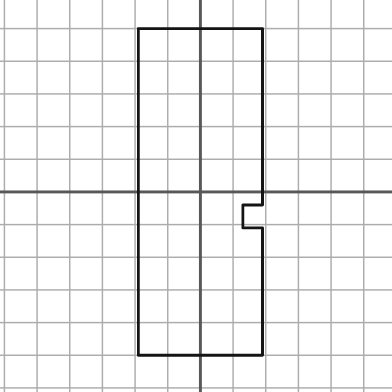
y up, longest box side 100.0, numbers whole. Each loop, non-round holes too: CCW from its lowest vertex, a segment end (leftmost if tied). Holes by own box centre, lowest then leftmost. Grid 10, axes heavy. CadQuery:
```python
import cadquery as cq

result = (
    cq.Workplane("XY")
    .moveTo(-19.0, -50.0)
    .lineTo(19.0, -50.0)
    .lineTo(19.0, -11.0)
    .lineTo(13.0, -11.0)
    .lineTo(13.0, -4.0)
    .lineTo(19.0, -4.0)
    .lineTo(19.0, 50.0)
    .lineTo(-19.0, 50.0)
    .close()
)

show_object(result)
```